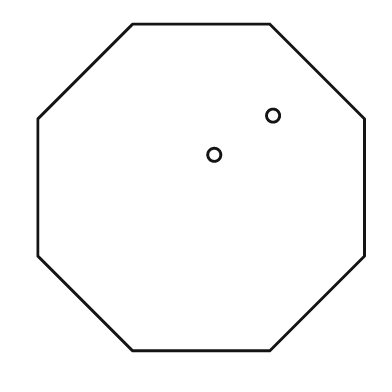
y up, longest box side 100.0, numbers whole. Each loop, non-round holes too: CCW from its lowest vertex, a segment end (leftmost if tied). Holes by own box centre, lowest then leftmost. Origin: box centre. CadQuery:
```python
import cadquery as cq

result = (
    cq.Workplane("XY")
    .moveTo(-21.0, -50.0)
    .lineTo(21.0, -50.0)
    .lineTo(50.0, -21.0)
    .lineTo(50.0, 21.0)
    .lineTo(21.0, 50.0)
    .lineTo(-21.0, 50.0)
    .lineTo(-50.0, 21.0)
    .lineTo(-50.0, -21.0)
    .close()
    .moveTo(4.0, 10.0)
    .circle(2.0)
    .moveTo(22.0, 22.0)
    .circle(2.0)
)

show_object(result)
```